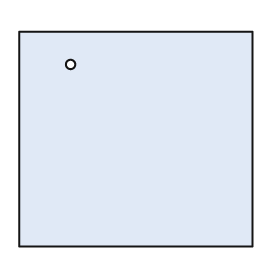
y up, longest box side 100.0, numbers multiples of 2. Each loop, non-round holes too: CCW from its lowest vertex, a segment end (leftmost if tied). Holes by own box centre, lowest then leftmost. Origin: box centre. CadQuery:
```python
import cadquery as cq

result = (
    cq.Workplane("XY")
    .moveTo(-50.0, -46.0)
    .lineTo(50.0, -46.0)
    .lineTo(50.0, 46.0)
    .lineTo(-50.0, 46.0)
    .close()
    .moveTo(-28.0, 32.0)
    .circle(2.0)
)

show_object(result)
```